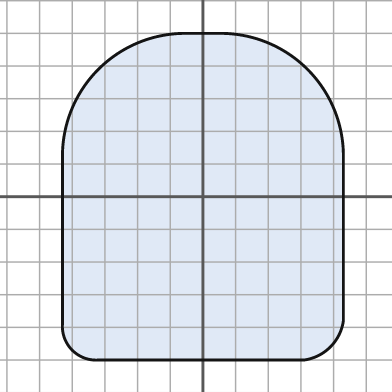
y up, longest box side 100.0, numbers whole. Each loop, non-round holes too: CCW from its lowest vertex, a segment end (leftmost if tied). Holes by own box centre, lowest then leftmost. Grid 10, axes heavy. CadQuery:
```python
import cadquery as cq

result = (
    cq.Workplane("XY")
    .moveTo(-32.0, -50.0)
    .lineTo(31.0, -50.0)
    .threePointArc((39.0, -46.0), (43.0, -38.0))
    .lineTo(43.0, 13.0)
    .threePointArc((32.0, 39.0), (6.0, 50.0))
    .lineTo(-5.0, 50.0)
    .threePointArc((-32.0, 39.0), (-43.0, 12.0))
    .lineTo(-43.0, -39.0)
    .threePointArc((-40.0, -47.0), (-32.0, -50.0))
    .close()
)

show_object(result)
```